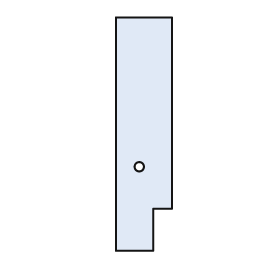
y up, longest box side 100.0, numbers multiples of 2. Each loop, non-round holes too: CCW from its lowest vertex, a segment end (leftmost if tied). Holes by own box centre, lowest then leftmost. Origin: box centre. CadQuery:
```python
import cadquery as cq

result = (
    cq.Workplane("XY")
    .moveTo(-12.0, -50.0)
    .lineTo(4.0, -50.0)
    .lineTo(4.0, -32.0)
    .lineTo(12.0, -32.0)
    .lineTo(12.0, 50.0)
    .lineTo(-12.0, 50.0)
    .close()
    .moveTo(-2.0, -14.0)
    .circle(2.0)
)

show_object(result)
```